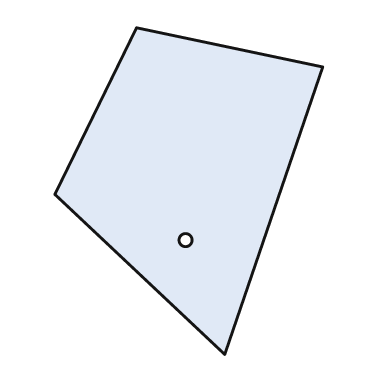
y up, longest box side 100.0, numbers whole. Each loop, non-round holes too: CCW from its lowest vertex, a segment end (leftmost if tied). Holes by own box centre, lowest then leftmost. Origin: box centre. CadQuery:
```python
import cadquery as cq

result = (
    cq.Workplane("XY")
    .moveTo(11.0, -50.0)
    .lineTo(41.0, 38.0)
    .lineTo(-16.0, 50.0)
    .lineTo(-41.0, -1.0)
    .close()
    .moveTo(-1.0, -15.0)
    .circle(2.0)
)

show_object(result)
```